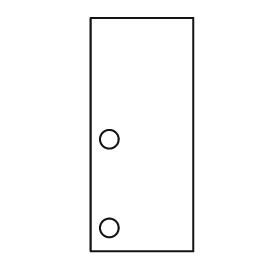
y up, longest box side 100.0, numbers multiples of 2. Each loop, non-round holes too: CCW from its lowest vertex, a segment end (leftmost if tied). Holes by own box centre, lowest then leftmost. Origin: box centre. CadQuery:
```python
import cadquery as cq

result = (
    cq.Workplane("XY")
    .moveTo(-22.0, -50.0)
    .lineTo(22.0, -50.0)
    .lineTo(22.0, 50.0)
    .lineTo(-22.0, 50.0)
    .close()
    .moveTo(-14.0, -40.0)
    .circle(4.0)
    .moveTo(-14.0, -2.0)
    .circle(4.0)
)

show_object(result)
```